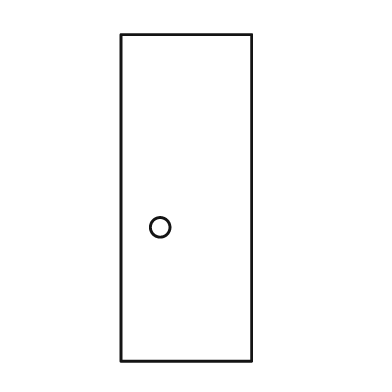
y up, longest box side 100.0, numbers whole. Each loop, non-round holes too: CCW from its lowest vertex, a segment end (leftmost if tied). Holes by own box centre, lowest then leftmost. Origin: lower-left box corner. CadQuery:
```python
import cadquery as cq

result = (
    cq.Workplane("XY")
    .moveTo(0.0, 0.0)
    .lineTo(40.0, 0.0)
    .lineTo(40.0, 100.0)
    .lineTo(0.0, 100.0)
    .close()
    .moveTo(12.0, 41.0)
    .circle(3.0)
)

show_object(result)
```